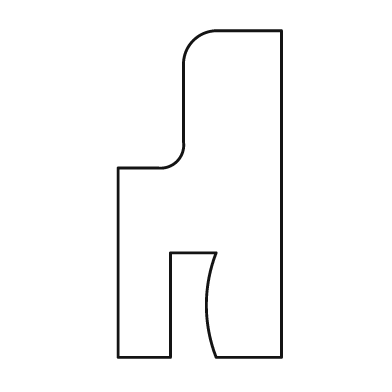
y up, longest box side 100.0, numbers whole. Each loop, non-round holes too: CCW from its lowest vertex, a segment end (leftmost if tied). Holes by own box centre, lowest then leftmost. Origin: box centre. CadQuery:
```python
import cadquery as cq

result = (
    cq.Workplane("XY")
    .moveTo(-25.0, -50.0)
    .lineTo(-9.0, -50.0)
    .lineTo(-9.0, -18.0)
    .lineTo(5.0, -18.0)
    .threePointArc((2.0, -34.0), (5.0, -50.0))
    .lineTo(25.0, -50.0)
    .lineTo(25.0, 50.0)
    .lineTo(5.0, 50.0)
    .threePointArc((-2.0, 47.0), (-5.0, 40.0))
    .lineTo(-5.0, 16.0)
    .threePointArc((-7.0, 10.0), (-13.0, 8.0))
    .lineTo(-25.0, 8.0)
    .close()
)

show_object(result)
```